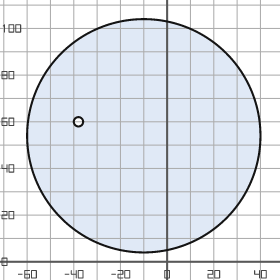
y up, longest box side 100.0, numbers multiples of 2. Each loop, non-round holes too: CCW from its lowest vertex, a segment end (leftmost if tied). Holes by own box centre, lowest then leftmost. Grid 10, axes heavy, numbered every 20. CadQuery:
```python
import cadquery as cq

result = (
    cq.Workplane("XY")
    .moveTo(-10.0, 54.0)
    .circle(50.0)
    .moveTo(-38.0, 60.0)
    .circle(2.0)
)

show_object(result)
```